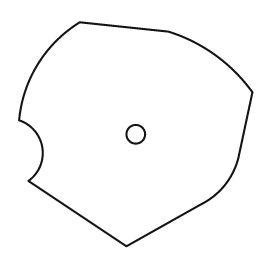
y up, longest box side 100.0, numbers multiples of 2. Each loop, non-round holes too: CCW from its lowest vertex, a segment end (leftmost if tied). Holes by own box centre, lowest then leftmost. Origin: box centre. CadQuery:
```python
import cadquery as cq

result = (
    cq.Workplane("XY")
    .moveTo(-4.0, -48.0)
    .lineTo(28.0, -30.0)
    .threePointArc((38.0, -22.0), (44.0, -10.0))
    .lineTo(50.0, 18.0)
    .threePointArc((34.0, 34.0), (14.0, 44.0))
    .lineTo(-24.0, 48.0)
    .threePointArc((-42.0, 30.0), (-50.0, 6.0))
    .threePointArc((-40.0, -6.0), (-46.0, -20.0))
    .close()
    .moveTo(0.0, 0.0)
    .circle(4.0)
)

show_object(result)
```